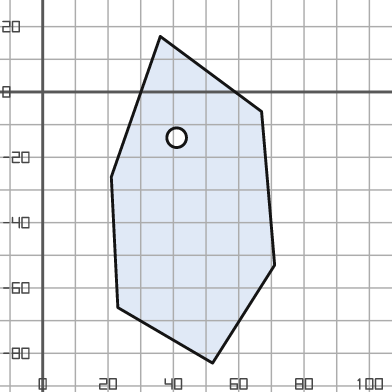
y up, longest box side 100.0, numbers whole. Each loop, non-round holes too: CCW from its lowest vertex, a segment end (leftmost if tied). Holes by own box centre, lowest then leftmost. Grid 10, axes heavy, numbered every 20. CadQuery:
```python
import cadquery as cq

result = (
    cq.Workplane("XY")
    .moveTo(52.0, -83.0)
    .lineTo(71.0, -53.0)
    .lineTo(67.0, -6.0)
    .lineTo(36.0, 17.0)
    .lineTo(21.0, -26.0)
    .lineTo(23.0, -66.0)
    .close()
    .moveTo(41.0, -14.0)
    .circle(3.0)
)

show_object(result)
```